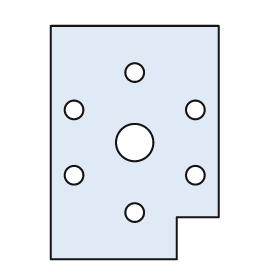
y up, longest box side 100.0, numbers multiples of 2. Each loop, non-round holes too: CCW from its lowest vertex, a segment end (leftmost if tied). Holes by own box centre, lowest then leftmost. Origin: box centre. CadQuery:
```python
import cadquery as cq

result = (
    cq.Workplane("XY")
    .moveTo(-36.0, -50.0)
    .lineTo(18.0, -50.0)
    .lineTo(18.0, -32.0)
    .lineTo(36.0, -32.0)
    .lineTo(36.0, 50.0)
    .lineTo(-36.0, 50.0)
    .close()
    .moveTo(0.0, -30.0)
    .circle(4.0)
    .moveTo(-26.0, -14.0)
    .circle(4.0)
    .moveTo(26.0, -14.0)
    .circle(4.0)
    .moveTo(0.0, 0.0)
    .circle(8.0)
    .moveTo(-26.0, 14.0)
    .circle(4.0)
    .moveTo(26.0, 14.0)
    .circle(4.0)
    .moveTo(0.0, 30.0)
    .circle(4.0)
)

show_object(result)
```